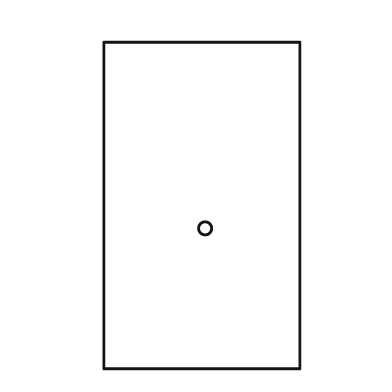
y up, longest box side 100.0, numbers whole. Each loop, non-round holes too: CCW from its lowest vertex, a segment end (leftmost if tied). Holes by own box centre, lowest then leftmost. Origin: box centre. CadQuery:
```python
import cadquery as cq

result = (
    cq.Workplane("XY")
    .moveTo(-30.0, -50.0)
    .lineTo(30.0, -50.0)
    .lineTo(30.0, 50.0)
    .lineTo(-30.0, 50.0)
    .close()
    .moveTo(1.0, -7.0)
    .circle(2.0)
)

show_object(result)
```